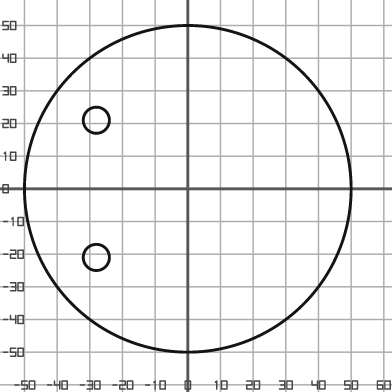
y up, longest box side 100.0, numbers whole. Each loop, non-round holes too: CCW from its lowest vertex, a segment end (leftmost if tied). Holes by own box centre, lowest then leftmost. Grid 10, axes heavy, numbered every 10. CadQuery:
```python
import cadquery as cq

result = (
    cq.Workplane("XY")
    .moveTo(0.0, 0.0)
    .circle(50.0)
    .moveTo(-28.0, -21.0)
    .circle(4.0)
    .moveTo(-28.0, 21.0)
    .circle(4.0)
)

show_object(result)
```